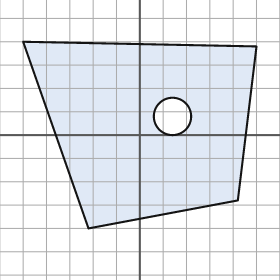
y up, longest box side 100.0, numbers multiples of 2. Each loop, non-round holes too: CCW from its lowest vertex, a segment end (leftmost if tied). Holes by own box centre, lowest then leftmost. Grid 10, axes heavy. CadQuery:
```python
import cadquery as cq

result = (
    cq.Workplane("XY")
    .moveTo(-22.0, -40.0)
    .lineTo(42.0, -28.0)
    .lineTo(50.0, 38.0)
    .lineTo(-50.0, 40.0)
    .close()
    .moveTo(14.0, 8.0)
    .circle(8.0)
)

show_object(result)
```